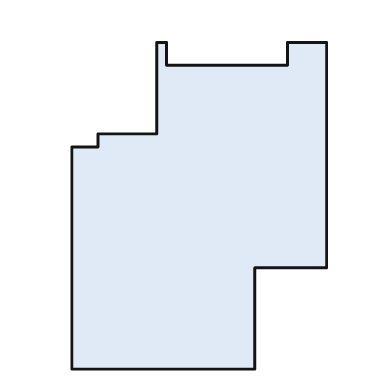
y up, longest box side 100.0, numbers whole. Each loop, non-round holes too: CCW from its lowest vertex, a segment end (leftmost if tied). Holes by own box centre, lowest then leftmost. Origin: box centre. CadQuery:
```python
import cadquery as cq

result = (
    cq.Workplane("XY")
    .moveTo(-39.0, -50.0)
    .lineTo(17.0, -50.0)
    .lineTo(17.0, -19.0)
    .lineTo(39.0, -19.0)
    .lineTo(39.0, 50.0)
    .lineTo(27.0, 50.0)
    .lineTo(27.0, 43.0)
    .lineTo(-10.0, 43.0)
    .lineTo(-10.0, 50.0)
    .lineTo(-13.0, 50.0)
    .lineTo(-13.0, 22.0)
    .lineTo(-31.0, 22.0)
    .lineTo(-31.0, 18.0)
    .lineTo(-39.0, 18.0)
    .close()
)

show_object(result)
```